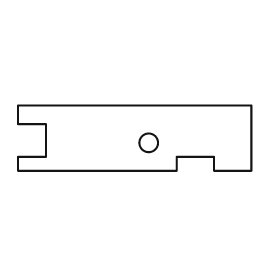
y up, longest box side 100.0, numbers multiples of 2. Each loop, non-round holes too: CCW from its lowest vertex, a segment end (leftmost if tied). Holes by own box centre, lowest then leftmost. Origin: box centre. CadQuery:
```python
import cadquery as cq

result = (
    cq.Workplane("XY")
    .moveTo(-50.0, -14.0)
    .lineTo(18.0, -14.0)
    .lineTo(18.0, -8.0)
    .lineTo(34.0, -8.0)
    .lineTo(34.0, -14.0)
    .lineTo(50.0, -14.0)
    .lineTo(50.0, 14.0)
    .lineTo(-50.0, 14.0)
    .lineTo(-50.0, 6.0)
    .lineTo(-38.0, 6.0)
    .lineTo(-38.0, -8.0)
    .lineTo(-50.0, -8.0)
    .close()
    .moveTo(6.0, -2.0)
    .circle(4.0)
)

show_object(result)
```